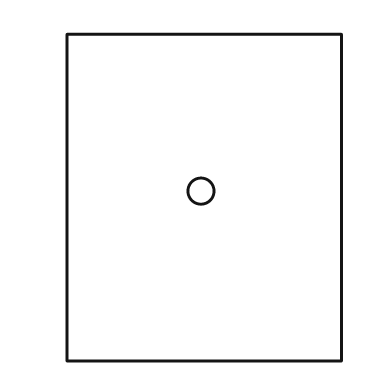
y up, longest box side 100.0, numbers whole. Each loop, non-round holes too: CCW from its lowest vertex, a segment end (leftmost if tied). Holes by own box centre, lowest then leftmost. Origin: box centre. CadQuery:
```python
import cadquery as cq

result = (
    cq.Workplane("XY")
    .moveTo(-42.0, -50.0)
    .lineTo(42.0, -50.0)
    .lineTo(42.0, 50.0)
    .lineTo(-42.0, 50.0)
    .close()
    .moveTo(-1.0, 2.0)
    .circle(4.0)
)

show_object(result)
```